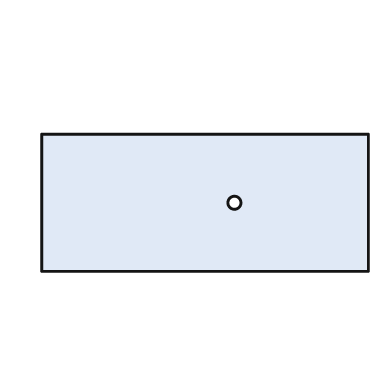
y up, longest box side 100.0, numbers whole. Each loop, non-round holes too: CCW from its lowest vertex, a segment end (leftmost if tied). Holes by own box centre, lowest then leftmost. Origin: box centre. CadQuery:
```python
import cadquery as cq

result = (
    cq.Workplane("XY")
    .moveTo(-50.0, -21.0)
    .lineTo(50.0, -21.0)
    .lineTo(50.0, 21.0)
    .lineTo(-50.0, 21.0)
    .close()
    .moveTo(9.0, 0.0)
    .circle(2.0)
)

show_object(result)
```